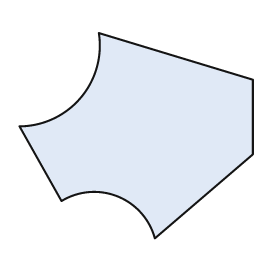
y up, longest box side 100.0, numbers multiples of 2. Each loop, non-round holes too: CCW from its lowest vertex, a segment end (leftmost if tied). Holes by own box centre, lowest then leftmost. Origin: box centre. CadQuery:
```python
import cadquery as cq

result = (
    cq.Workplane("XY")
    .moveTo(8.0, -44.0)
    .lineTo(50.0, -8.0)
    .lineTo(50.0, 24.0)
    .lineTo(-16.0, 44.0)
    .threePointArc((-24.0, 16.0), (-50.0, 4.0))
    .lineTo(-32.0, -28.0)
    .threePointArc((-8.0, -26.0), (8.0, -44.0))
    .close()
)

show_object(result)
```